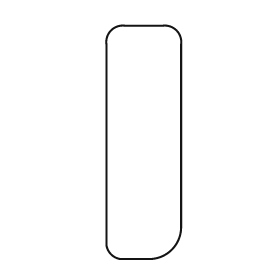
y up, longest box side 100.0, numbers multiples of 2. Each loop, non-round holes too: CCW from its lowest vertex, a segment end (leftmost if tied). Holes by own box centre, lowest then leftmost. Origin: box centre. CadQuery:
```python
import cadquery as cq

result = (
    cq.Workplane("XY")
    .moveTo(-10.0, -50.0)
    .lineTo(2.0, -50.0)
    .threePointArc((12.0, -46.0), (16.0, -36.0))
    .lineTo(16.0, 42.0)
    .threePointArc((14.0, 48.0), (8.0, 50.0))
    .lineTo(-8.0, 50.0)
    .threePointArc((-14.0, 48.0), (-16.0, 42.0))
    .lineTo(-16.0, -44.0)
    .threePointArc((-14.0, -48.0), (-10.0, -50.0))
    .close()
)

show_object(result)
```